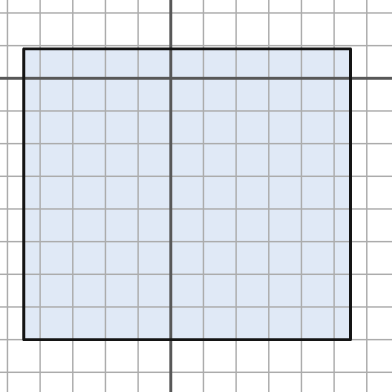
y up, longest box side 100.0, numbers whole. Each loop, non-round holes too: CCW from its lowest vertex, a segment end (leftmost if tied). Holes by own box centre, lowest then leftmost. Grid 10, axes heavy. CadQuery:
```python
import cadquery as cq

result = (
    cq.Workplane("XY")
    .moveTo(-45.0, -80.0)
    .lineTo(55.0, -80.0)
    .lineTo(55.0, 9.0)
    .lineTo(-45.0, 9.0)
    .close()
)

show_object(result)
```